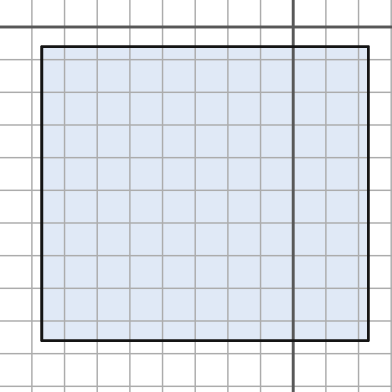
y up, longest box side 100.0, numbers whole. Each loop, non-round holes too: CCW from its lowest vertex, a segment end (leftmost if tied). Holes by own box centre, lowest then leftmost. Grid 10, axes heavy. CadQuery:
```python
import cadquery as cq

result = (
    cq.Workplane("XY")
    .moveTo(-77.0, -96.0)
    .lineTo(23.0, -96.0)
    .lineTo(23.0, -6.0)
    .lineTo(-77.0, -6.0)
    .close()
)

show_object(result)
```